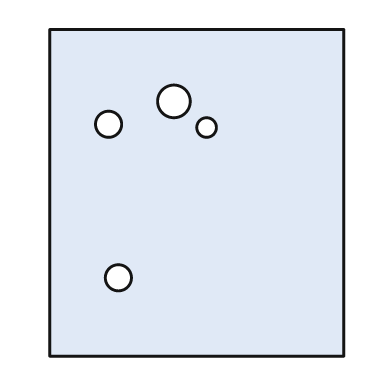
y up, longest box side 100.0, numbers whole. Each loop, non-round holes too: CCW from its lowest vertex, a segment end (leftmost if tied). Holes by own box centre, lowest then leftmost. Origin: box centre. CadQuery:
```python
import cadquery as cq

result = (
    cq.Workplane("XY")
    .moveTo(-45.0, -50.0)
    .lineTo(45.0, -50.0)
    .lineTo(45.0, 50.0)
    .lineTo(-45.0, 50.0)
    .close()
    .moveTo(-24.0, -26.0)
    .circle(4.0)
    .moveTo(3.0, 20.0)
    .circle(3.0)
    .moveTo(-27.0, 21.0)
    .circle(4.0)
    .moveTo(-7.0, 28.0)
    .circle(5.0)
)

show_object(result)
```